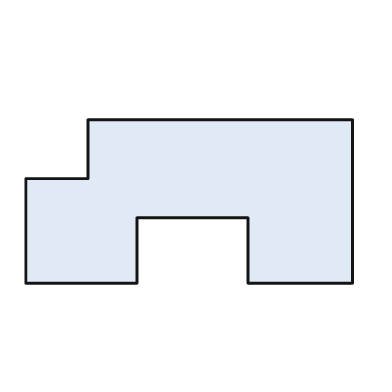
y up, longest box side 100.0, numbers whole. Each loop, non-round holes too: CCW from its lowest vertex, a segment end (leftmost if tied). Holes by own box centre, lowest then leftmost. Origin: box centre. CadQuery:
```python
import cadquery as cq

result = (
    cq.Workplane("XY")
    .moveTo(-50.0, -25.0)
    .lineTo(-16.0, -25.0)
    .lineTo(-16.0, -5.0)
    .lineTo(18.0, -5.0)
    .lineTo(18.0, -25.0)
    .lineTo(50.0, -25.0)
    .lineTo(50.0, 25.0)
    .lineTo(-31.0, 25.0)
    .lineTo(-31.0, 7.0)
    .lineTo(-50.0, 7.0)
    .close()
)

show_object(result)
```